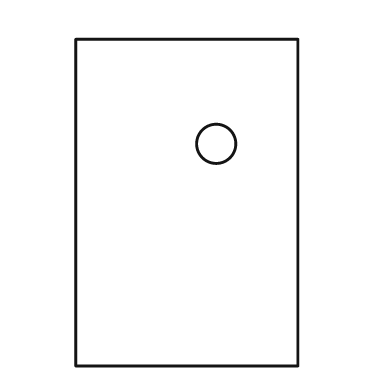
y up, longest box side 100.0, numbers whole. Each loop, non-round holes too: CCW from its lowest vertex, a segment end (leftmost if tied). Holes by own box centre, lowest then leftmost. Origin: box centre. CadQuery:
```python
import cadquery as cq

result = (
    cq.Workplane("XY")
    .moveTo(-34.0, -50.0)
    .lineTo(34.0, -50.0)
    .lineTo(34.0, 50.0)
    .lineTo(-34.0, 50.0)
    .close()
    .moveTo(9.0, 18.0)
    .circle(6.0)
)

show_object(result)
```